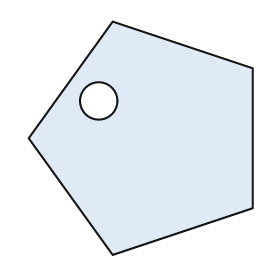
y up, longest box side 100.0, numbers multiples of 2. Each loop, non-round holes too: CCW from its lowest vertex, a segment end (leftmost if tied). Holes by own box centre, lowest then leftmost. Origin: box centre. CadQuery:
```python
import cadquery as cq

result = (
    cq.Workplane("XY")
    .moveTo(-12.0, -50.0)
    .lineTo(48.0, -30.0)
    .lineTo(48.0, 30.0)
    .lineTo(-12.0, 50.0)
    .lineTo(-48.0, 0.0)
    .close()
    .moveTo(-18.0, 16.0)
    .circle(8.0)
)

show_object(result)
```